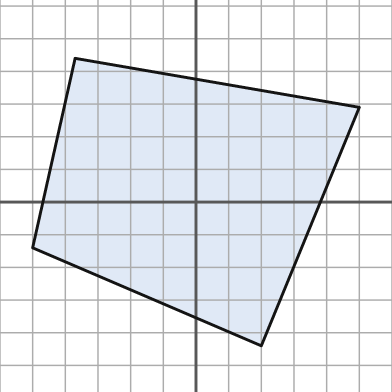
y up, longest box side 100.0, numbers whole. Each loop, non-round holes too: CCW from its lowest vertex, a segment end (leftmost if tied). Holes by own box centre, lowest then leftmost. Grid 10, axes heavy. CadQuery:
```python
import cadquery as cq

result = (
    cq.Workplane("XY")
    .moveTo(20.0, -44.0)
    .lineTo(50.0, 29.0)
    .lineTo(-37.0, 44.0)
    .lineTo(-50.0, -14.0)
    .close()
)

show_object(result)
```